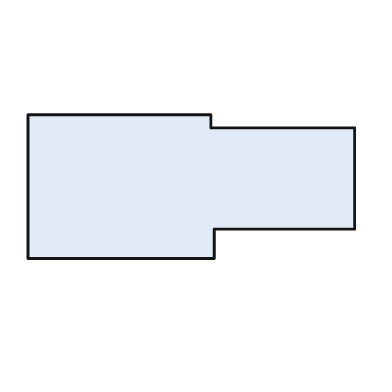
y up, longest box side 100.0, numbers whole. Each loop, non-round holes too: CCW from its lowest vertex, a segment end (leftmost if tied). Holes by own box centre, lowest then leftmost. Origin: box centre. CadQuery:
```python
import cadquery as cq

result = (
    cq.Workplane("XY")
    .moveTo(-50.0, -22.0)
    .lineTo(7.0, -22.0)
    .lineTo(7.0, -13.0)
    .lineTo(50.0, -13.0)
    .lineTo(50.0, 18.0)
    .lineTo(6.0, 18.0)
    .lineTo(6.0, 22.0)
    .lineTo(-50.0, 22.0)
    .close()
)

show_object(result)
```